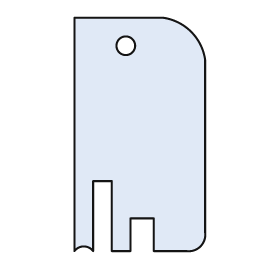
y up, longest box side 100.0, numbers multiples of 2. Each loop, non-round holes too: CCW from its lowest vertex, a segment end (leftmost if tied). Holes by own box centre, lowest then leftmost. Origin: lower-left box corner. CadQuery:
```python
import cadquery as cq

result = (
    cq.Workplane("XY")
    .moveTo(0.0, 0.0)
    .threePointArc((4.0, 2.0), (8.0, 0.0))
    .lineTo(8.0, 30.0)
    .lineTo(16.0, 30.0)
    .lineTo(16.0, 0.0)
    .lineTo(24.0, 0.0)
    .lineTo(24.0, 14.0)
    .lineTo(34.0, 14.0)
    .lineTo(34.0, 0.0)
    .lineTo(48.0, 0.0)
    .threePointArc((54.0, 2.0), (56.0, 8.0))
    .lineTo(56.0, 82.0)
    .threePointArc((50.0, 94.0), (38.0, 100.0))
    .lineTo(0.0, 100.0)
    .close()
    .moveTo(22.0, 88.0)
    .circle(4.0)
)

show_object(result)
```